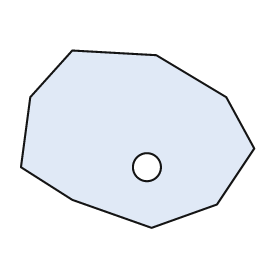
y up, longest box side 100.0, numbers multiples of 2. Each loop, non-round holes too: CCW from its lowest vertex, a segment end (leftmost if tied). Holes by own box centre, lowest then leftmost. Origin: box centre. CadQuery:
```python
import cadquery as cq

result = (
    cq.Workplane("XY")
    .moveTo(6.0, -38.0)
    .lineTo(34.0, -28.0)
    .lineTo(50.0, -4.0)
    .lineTo(38.0, 18.0)
    .lineTo(8.0, 36.0)
    .lineTo(-28.0, 38.0)
    .lineTo(-46.0, 18.0)
    .lineTo(-50.0, -12.0)
    .lineTo(-28.0, -26.0)
    .close()
    .moveTo(4.0, -12.0)
    .circle(6.0)
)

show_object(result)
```